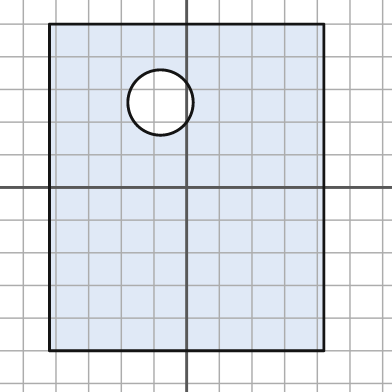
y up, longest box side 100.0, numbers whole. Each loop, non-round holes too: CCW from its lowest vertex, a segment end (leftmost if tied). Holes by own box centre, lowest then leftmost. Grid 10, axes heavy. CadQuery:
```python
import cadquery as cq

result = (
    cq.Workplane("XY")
    .moveTo(-42.0, -50.0)
    .lineTo(42.0, -50.0)
    .lineTo(42.0, 50.0)
    .lineTo(-42.0, 50.0)
    .close()
    .moveTo(-8.0, 26.0)
    .circle(10.0)
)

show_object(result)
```